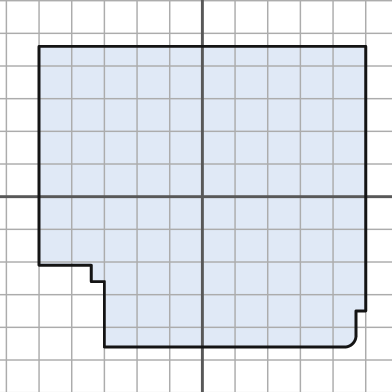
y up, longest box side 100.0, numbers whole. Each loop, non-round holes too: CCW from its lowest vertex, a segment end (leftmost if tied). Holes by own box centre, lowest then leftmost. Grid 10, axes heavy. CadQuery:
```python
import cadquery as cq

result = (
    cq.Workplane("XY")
    .moveTo(-30.0, -46.0)
    .lineTo(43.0, -46.0)
    .threePointArc((46.0, -45.0), (47.0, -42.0))
    .lineTo(47.0, -35.0)
    .lineTo(50.0, -35.0)
    .lineTo(50.0, 46.0)
    .lineTo(-50.0, 46.0)
    .lineTo(-50.0, -21.0)
    .lineTo(-34.0, -21.0)
    .lineTo(-34.0, -26.0)
    .lineTo(-30.0, -26.0)
    .close()
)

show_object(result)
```